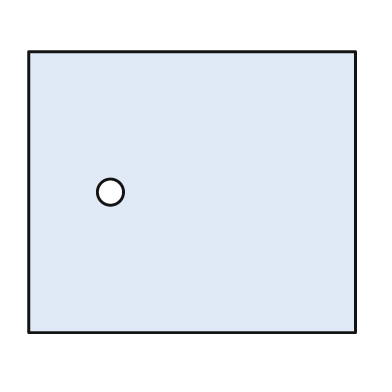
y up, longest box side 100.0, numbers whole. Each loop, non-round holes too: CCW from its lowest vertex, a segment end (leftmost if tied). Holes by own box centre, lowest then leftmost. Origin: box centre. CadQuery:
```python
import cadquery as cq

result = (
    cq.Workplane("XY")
    .moveTo(-50.0, -43.0)
    .lineTo(50.0, -43.0)
    .lineTo(50.0, 43.0)
    .lineTo(-50.0, 43.0)
    .close()
    .moveTo(-25.0, 0.0)
    .circle(4.0)
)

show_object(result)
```